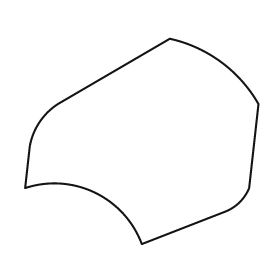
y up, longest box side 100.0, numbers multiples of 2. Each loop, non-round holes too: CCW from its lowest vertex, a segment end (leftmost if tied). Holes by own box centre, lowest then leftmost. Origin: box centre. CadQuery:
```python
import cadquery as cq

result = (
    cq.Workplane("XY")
    .moveTo(0.0, -44.0)
    .lineTo(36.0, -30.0)
    .threePointArc((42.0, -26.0), (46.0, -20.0))
    .lineTo(50.0, 16.0)
    .threePointArc((34.0, 34.0), (12.0, 44.0))
    .lineTo(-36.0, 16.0)
    .threePointArc((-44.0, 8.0), (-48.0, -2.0))
    .lineTo(-50.0, -20.0)
    .threePointArc((-20.0, -22.0), (0.0, -44.0))
    .close()
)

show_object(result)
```